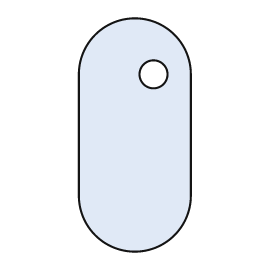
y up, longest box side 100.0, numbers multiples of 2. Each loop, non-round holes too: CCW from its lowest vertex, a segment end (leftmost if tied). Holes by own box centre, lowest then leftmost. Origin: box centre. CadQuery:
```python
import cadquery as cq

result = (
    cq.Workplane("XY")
    .moveTo(-24.0, -26.0)
    .threePointArc((0.0, -50.0), (24.0, -26.0))
    .lineTo(24.0, 26.0)
    .threePointArc((0.0, 50.0), (-24.0, 26.0))
    .close()
    .moveTo(8.0, 26.0)
    .circle(6.0)
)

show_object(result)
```